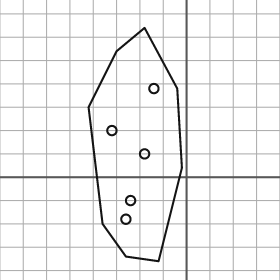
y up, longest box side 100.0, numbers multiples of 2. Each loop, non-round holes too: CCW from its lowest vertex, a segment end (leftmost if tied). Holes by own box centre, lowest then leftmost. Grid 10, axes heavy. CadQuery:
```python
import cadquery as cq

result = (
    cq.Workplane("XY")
    .moveTo(-12.0, -36.0)
    .lineTo(-2.0, 4.0)
    .lineTo(-4.0, 38.0)
    .lineTo(-18.0, 64.0)
    .lineTo(-30.0, 54.0)
    .lineTo(-42.0, 30.0)
    .lineTo(-36.0, -20.0)
    .lineTo(-26.0, -34.0)
    .close()
    .moveTo(-26.0, -18.0)
    .circle(2.0)
    .moveTo(-24.0, -10.0)
    .circle(2.0)
    .moveTo(-18.0, 10.0)
    .circle(2.0)
    .moveTo(-32.0, 20.0)
    .circle(2.0)
    .moveTo(-14.0, 38.0)
    .circle(2.0)
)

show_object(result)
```